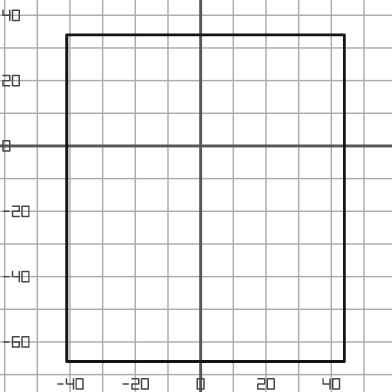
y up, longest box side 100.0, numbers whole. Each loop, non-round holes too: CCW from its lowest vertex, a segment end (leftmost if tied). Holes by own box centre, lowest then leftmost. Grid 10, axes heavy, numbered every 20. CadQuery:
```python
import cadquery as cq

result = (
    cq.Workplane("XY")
    .moveTo(-41.0, -66.0)
    .lineTo(44.0, -66.0)
    .lineTo(44.0, 34.0)
    .lineTo(-41.0, 34.0)
    .close()
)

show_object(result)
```